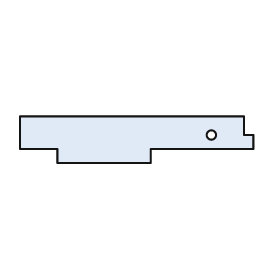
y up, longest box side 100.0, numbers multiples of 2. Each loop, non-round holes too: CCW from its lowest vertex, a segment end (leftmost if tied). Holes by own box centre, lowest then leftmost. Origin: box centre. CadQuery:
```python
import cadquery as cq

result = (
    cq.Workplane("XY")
    .moveTo(-34.0, -10.0)
    .lineTo(6.0, -10.0)
    .lineTo(6.0, -4.0)
    .lineTo(50.0, -4.0)
    .lineTo(50.0, 2.0)
    .lineTo(46.0, 2.0)
    .lineTo(46.0, 10.0)
    .lineTo(-50.0, 10.0)
    .lineTo(-50.0, -4.0)
    .lineTo(-34.0, -4.0)
    .close()
    .moveTo(32.0, 2.0)
    .circle(2.0)
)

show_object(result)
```